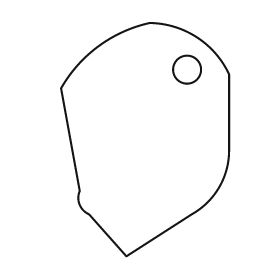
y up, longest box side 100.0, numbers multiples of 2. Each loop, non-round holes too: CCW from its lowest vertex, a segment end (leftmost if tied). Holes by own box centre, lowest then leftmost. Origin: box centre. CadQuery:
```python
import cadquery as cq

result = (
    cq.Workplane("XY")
    .moveTo(-8.0, -50.0)
    .lineTo(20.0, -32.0)
    .threePointArc((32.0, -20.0), (36.0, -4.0))
    .lineTo(36.0, 28.0)
    .threePointArc((22.0, 44.0), (2.0, 50.0))
    .threePointArc((-20.0, 40.0), (-36.0, 22.0))
    .lineTo(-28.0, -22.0)
    .threePointArc((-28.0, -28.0), (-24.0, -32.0))
    .close()
    .moveTo(18.0, 30.0)
    .circle(6.0)
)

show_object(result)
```